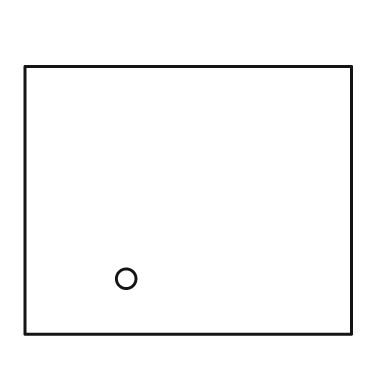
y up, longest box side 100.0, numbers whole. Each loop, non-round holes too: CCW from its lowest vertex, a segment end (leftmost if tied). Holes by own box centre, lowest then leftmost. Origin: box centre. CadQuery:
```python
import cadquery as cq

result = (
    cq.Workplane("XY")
    .moveTo(-50.0, -41.0)
    .lineTo(50.0, -41.0)
    .lineTo(50.0, 41.0)
    .lineTo(-50.0, 41.0)
    .close()
    .moveTo(-19.0, -24.0)
    .circle(3.0)
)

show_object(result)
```